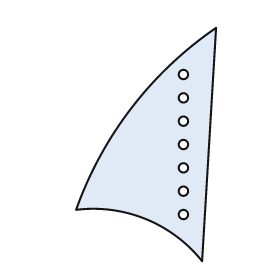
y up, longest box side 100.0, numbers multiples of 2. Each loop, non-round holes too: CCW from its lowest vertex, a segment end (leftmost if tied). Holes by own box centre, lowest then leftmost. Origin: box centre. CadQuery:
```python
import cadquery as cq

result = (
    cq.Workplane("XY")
    .moveTo(24.0, -50.0)
    .lineTo(30.0, 50.0)
    .threePointArc((-6.0, 16.0), (-30.0, -28.0))
    .threePointArc((0.0, -32.0), (24.0, -50.0))
    .close()
    .moveTo(16.0, -30.0)
    .circle(2.0)
    .moveTo(16.0, -20.0)
    .circle(2.0)
    .moveTo(16.0, -10.0)
    .circle(2.0)
    .moveTo(16.0, 0.0)
    .circle(2.0)
    .moveTo(16.0, 10.0)
    .circle(2.0)
    .moveTo(16.0, 20.0)
    .circle(2.0)
    .moveTo(16.0, 30.0)
    .circle(2.0)
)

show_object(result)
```